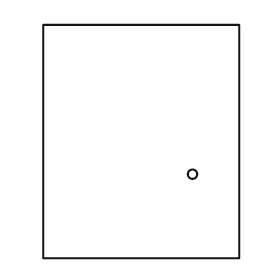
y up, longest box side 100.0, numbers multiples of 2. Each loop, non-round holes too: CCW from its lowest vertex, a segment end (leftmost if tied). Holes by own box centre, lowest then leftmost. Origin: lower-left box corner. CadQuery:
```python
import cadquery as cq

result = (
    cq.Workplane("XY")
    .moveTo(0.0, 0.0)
    .lineTo(84.0, 0.0)
    .lineTo(84.0, 100.0)
    .lineTo(0.0, 100.0)
    .close()
    .moveTo(64.0, 36.0)
    .circle(2.0)
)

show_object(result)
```